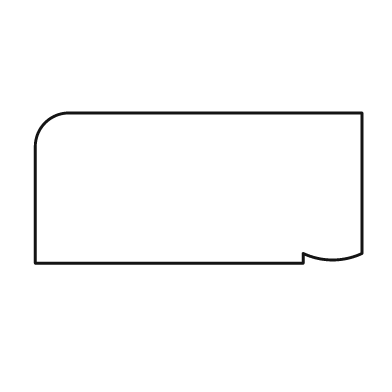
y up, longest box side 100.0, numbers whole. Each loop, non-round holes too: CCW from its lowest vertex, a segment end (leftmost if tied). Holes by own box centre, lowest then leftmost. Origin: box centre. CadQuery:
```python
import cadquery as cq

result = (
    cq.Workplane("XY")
    .moveTo(-50.0, -23.0)
    .lineTo(32.0, -23.0)
    .lineTo(32.0, -20.0)
    .threePointArc((41.0, -22.0), (50.0, -20.0))
    .lineTo(50.0, 23.0)
    .lineTo(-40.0, 23.0)
    .threePointArc((-47.0, 20.0), (-50.0, 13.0))
    .close()
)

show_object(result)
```